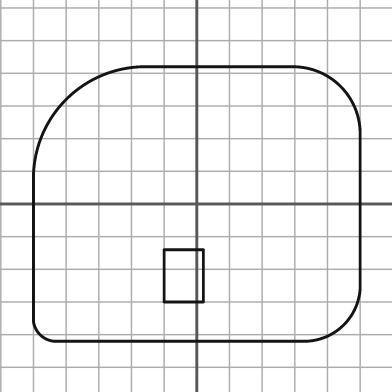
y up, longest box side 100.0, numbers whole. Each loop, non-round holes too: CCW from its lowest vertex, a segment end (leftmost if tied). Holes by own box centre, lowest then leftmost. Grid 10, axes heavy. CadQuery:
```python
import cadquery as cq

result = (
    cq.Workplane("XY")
    .moveTo(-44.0, -42.0)
    .lineTo(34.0, -42.0)
    .threePointArc((45.0, -37.0), (50.0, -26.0))
    .lineTo(50.0, 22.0)
    .threePointArc((44.0, 36.0), (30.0, 42.0))
    .lineTo(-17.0, 42.0)
    .threePointArc((-40.0, 32.0), (-50.0, 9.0))
    .lineTo(-50.0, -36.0)
    .threePointArc((-48.0, -40.0), (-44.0, -42.0))
    .close()
    .moveTo(-10.0, -30.0)
    .lineTo(2.0, -30.0)
    .lineTo(2.0, -14.0)
    .lineTo(-10.0, -14.0)
    .close()
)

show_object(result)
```